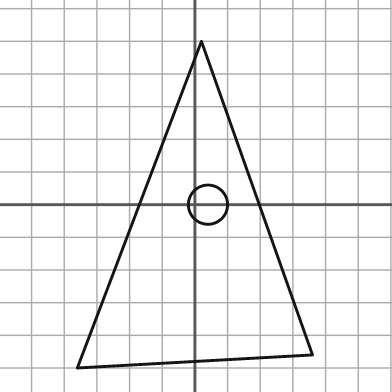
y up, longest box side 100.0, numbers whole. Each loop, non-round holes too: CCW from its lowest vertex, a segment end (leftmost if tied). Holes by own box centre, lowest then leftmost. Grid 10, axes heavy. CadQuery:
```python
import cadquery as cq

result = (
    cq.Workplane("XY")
    .moveTo(-36.0, -50.0)
    .lineTo(36.0, -46.0)
    .lineTo(2.0, 50.0)
    .close()
    .moveTo(4.0, 0.0)
    .circle(6.0)
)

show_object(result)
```